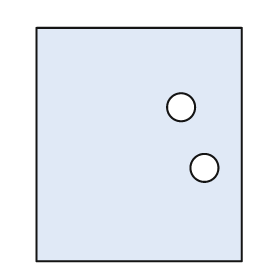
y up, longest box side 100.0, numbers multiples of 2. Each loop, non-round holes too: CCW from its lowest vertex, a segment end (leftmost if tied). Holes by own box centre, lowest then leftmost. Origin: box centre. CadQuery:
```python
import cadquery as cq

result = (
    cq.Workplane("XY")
    .moveTo(-44.0, -50.0)
    .lineTo(44.0, -50.0)
    .lineTo(44.0, 50.0)
    .lineTo(-44.0, 50.0)
    .close()
    .moveTo(28.0, -10.0)
    .circle(6.0)
    .moveTo(18.0, 16.0)
    .circle(6.0)
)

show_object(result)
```